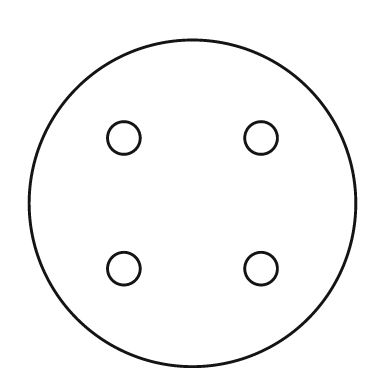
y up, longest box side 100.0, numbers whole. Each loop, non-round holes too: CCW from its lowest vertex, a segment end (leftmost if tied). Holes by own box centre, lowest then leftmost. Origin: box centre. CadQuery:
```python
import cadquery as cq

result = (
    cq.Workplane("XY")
    .moveTo(0.0, 0.0)
    .circle(50.0)
    .moveTo(-21.0, -20.0)
    .circle(5.0)
    .moveTo(21.0, -20.0)
    .circle(5.0)
    .moveTo(-21.0, 20.0)
    .circle(5.0)
    .moveTo(21.0, 20.0)
    .circle(5.0)
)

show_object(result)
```